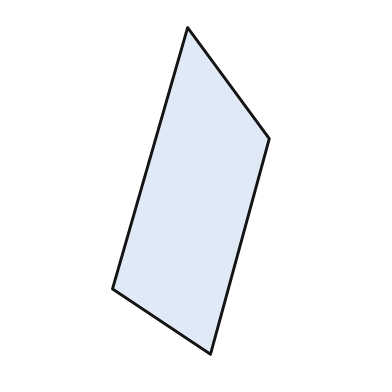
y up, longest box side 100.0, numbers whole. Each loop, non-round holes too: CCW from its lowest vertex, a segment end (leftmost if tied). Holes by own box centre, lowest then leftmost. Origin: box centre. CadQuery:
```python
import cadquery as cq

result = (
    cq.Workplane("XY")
    .moveTo(6.0, -50.0)
    .lineTo(24.0, 16.0)
    .lineTo(-1.0, 50.0)
    .lineTo(-24.0, -30.0)
    .close()
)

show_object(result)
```